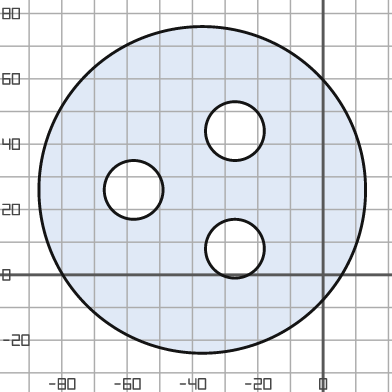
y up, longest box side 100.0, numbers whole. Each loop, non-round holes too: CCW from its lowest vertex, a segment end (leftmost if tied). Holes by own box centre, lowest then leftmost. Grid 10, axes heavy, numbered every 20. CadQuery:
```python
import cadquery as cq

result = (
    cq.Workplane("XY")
    .moveTo(-37.0, 26.0)
    .circle(50.0)
    .moveTo(-27.0, 8.0)
    .circle(9.0)
    .moveTo(-58.0, 26.0)
    .circle(9.0)
    .moveTo(-27.0, 44.0)
    .circle(9.0)
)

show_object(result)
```